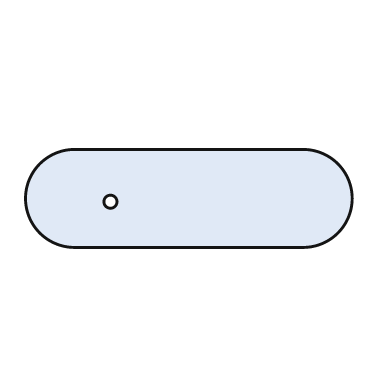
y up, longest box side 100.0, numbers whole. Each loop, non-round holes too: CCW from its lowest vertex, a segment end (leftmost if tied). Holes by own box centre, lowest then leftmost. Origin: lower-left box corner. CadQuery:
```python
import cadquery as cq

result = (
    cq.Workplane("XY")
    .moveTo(15.0, 0.0)
    .lineTo(85.0, 0.0)
    .threePointArc((100.0, 15.0), (85.0, 30.0))
    .lineTo(15.0, 30.0)
    .threePointArc((0.0, 15.0), (15.0, 0.0))
    .close()
    .moveTo(26.0, 14.0)
    .circle(2.0)
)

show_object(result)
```